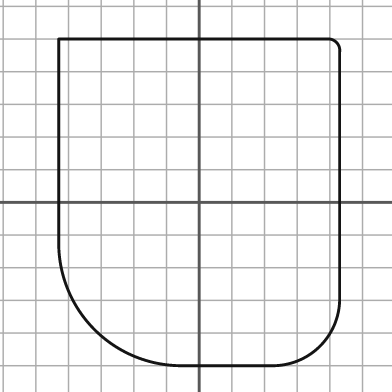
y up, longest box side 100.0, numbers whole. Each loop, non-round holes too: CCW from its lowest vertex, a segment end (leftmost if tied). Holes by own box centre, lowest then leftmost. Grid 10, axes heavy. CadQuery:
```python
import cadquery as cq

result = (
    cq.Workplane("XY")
    .moveTo(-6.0, -50.0)
    .lineTo(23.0, -50.0)
    .threePointArc((37.0, -44.0), (43.0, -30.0))
    .lineTo(43.0, 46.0)
    .threePointArc((42.0, 49.0), (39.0, 50.0))
    .lineTo(-43.0, 50.0)
    .lineTo(-43.0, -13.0)
    .threePointArc((-32.0, -39.0), (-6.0, -50.0))
    .close()
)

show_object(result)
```